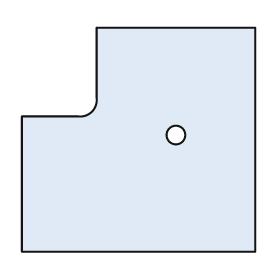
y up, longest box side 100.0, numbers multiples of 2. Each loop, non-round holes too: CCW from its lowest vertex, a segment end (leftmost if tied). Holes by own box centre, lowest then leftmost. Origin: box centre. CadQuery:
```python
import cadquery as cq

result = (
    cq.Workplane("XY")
    .moveTo(-50.0, -48.0)
    .lineTo(50.0, -48.0)
    .lineTo(50.0, 48.0)
    .lineTo(-18.0, 48.0)
    .lineTo(-18.0, 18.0)
    .threePointArc((-20.0, 12.0), (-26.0, 10.0))
    .lineTo(-50.0, 10.0)
    .close()
    .moveTo(16.0, 2.0)
    .circle(4.0)
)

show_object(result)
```